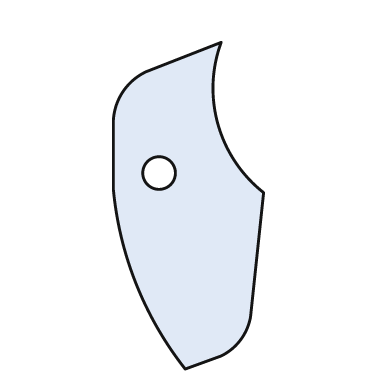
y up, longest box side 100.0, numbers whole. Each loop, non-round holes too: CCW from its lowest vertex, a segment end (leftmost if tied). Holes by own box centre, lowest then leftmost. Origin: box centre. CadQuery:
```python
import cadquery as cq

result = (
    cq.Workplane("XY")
    .moveTo(-1.0, -50.0)
    .lineTo(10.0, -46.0)
    .threePointArc((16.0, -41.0), (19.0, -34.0))
    .lineTo(23.0, 4.0)
    .threePointArc((9.0, 25.0), (10.0, 50.0))
    .lineTo(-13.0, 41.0)
    .threePointArc((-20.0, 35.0), (-23.0, 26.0))
    .lineTo(-23.0, 5.0)
    .threePointArc((-16.0, -24.0), (-1.0, -50.0))
    .close()
    .moveTo(-9.0, 10.0)
    .circle(5.0)
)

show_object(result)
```